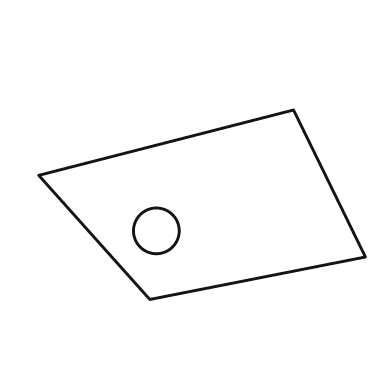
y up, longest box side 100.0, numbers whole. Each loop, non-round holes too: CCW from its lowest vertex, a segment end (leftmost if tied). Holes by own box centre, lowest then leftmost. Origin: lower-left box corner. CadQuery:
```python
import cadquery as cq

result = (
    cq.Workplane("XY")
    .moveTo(34.0, 0.0)
    .lineTo(100.0, 13.0)
    .lineTo(78.0, 58.0)
    .lineTo(0.0, 38.0)
    .close()
    .moveTo(36.0, 21.0)
    .circle(7.0)
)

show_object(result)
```